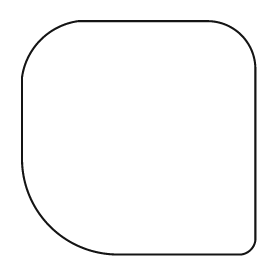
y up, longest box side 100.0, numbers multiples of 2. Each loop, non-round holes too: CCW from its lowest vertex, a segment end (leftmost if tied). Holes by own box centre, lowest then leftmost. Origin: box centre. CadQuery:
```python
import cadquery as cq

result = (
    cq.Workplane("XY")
    .moveTo(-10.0, -50.0)
    .lineTo(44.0, -50.0)
    .threePointArc((48.0, -48.0), (50.0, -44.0))
    .lineTo(50.0, 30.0)
    .threePointArc((44.0, 44.0), (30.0, 50.0))
    .lineTo(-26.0, 50.0)
    .threePointArc((-42.0, 42.0), (-50.0, 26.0))
    .lineTo(-50.0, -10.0)
    .threePointArc((-38.0, -38.0), (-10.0, -50.0))
    .close()
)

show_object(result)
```